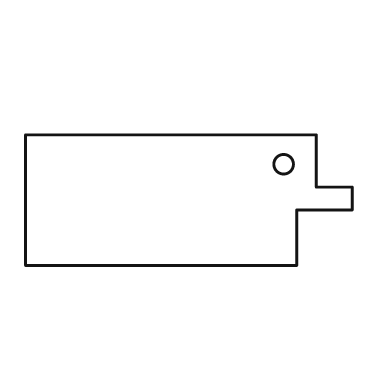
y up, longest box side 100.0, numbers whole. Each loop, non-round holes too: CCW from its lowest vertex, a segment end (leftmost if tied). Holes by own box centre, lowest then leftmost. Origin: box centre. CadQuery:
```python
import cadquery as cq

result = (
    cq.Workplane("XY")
    .moveTo(-50.0, -20.0)
    .lineTo(33.0, -20.0)
    .lineTo(33.0, -3.0)
    .lineTo(50.0, -3.0)
    .lineTo(50.0, 4.0)
    .lineTo(39.0, 4.0)
    .lineTo(39.0, 20.0)
    .lineTo(-50.0, 20.0)
    .close()
    .moveTo(29.0, 11.0)
    .circle(3.0)
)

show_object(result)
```